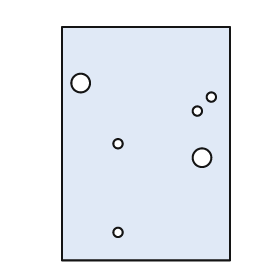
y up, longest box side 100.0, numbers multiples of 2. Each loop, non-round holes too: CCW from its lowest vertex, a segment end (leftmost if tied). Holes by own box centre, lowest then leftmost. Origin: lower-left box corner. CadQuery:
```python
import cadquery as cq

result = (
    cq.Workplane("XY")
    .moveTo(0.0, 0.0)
    .lineTo(72.0, 0.0)
    .lineTo(72.0, 100.0)
    .lineTo(0.0, 100.0)
    .close()
    .moveTo(24.0, 12.0)
    .circle(2.0)
    .moveTo(60.0, 44.0)
    .circle(4.0)
    .moveTo(24.0, 50.0)
    .circle(2.0)
    .moveTo(58.0, 64.0)
    .circle(2.0)
    .moveTo(64.0, 70.0)
    .circle(2.0)
    .moveTo(8.0, 76.0)
    .circle(4.0)
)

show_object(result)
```